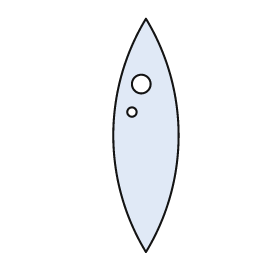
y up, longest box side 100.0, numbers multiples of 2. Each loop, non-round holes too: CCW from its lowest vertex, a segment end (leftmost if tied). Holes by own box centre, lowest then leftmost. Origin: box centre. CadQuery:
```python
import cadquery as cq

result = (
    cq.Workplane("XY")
    .moveTo(0.0, -50.0)
    .threePointArc((14.0, 0.0), (0.0, 50.0))
    .threePointArc((-14.0, 0.0), (0.0, -50.0))
    .close()
    .moveTo(-6.0, 10.0)
    .circle(2.0)
    .moveTo(-2.0, 22.0)
    .circle(4.0)
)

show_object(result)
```